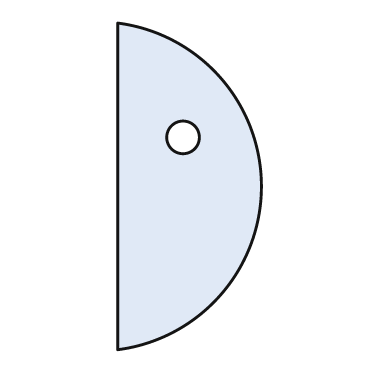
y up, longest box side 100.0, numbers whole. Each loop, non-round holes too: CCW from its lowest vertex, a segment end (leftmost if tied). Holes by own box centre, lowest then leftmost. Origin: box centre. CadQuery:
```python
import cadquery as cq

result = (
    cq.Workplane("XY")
    .moveTo(-22.0, -50.0)
    .threePointArc((22.0, 0.0), (-22.0, 50.0))
    .close()
    .moveTo(-2.0, 15.0)
    .circle(5.0)
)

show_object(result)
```